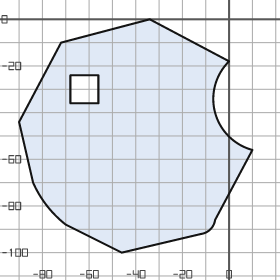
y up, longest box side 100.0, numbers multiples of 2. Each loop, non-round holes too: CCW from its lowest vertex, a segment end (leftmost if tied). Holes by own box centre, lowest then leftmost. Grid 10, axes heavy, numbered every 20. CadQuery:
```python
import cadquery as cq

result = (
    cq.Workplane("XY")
    .moveTo(-46.0, -100.0)
    .lineTo(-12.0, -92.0)
    .threePointArc((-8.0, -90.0), (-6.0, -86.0))
    .lineTo(10.0, -56.0)
    .threePointArc((-6.0, -40.0), (0.0, -18.0))
    .lineTo(-34.0, 0.0)
    .lineTo(-72.0, -10.0)
    .lineTo(-90.0, -44.0)
    .lineTo(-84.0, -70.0)
    .threePointArc((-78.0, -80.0), (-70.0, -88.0))
    .close()
    .moveTo(-68.0, -36.0)
    .lineTo(-56.0, -36.0)
    .lineTo(-56.0, -24.0)
    .lineTo(-68.0, -24.0)
    .close()
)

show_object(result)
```